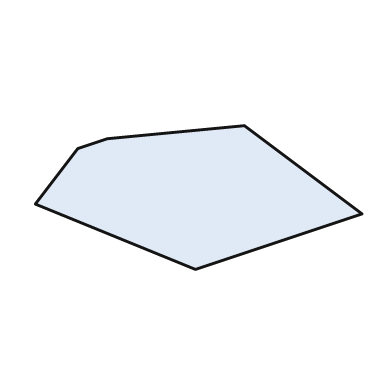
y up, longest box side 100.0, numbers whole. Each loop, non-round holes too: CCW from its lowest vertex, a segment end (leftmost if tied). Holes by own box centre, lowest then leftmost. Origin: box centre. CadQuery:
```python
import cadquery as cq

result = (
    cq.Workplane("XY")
    .moveTo(-1.0, -22.0)
    .lineTo(50.0, -5.0)
    .lineTo(14.0, 22.0)
    .lineTo(-28.0, 18.0)
    .lineTo(-37.0, 15.0)
    .lineTo(-50.0, -2.0)
    .close()
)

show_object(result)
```